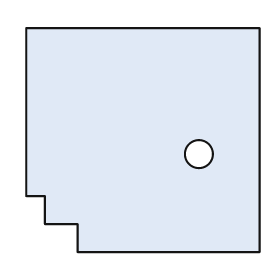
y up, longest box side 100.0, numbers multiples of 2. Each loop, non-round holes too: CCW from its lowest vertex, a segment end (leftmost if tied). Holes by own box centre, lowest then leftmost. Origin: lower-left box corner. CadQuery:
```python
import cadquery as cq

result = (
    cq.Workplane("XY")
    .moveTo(22.0, 0.0)
    .lineTo(100.0, 0.0)
    .lineTo(100.0, 96.0)
    .lineTo(0.0, 96.0)
    .lineTo(0.0, 24.0)
    .lineTo(8.0, 24.0)
    .lineTo(8.0, 12.0)
    .lineTo(22.0, 12.0)
    .close()
    .moveTo(74.0, 42.0)
    .circle(6.0)
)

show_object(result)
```